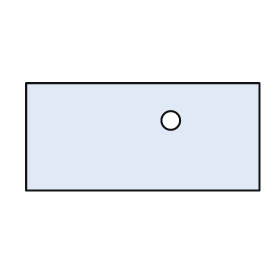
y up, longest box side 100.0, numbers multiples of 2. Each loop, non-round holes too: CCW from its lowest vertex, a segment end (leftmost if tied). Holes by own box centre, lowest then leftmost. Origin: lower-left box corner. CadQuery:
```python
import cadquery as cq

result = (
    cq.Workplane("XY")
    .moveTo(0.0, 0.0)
    .lineTo(100.0, 0.0)
    .lineTo(100.0, 46.0)
    .lineTo(0.0, 46.0)
    .close()
    .moveTo(62.0, 30.0)
    .circle(4.0)
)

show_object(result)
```